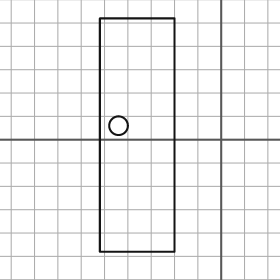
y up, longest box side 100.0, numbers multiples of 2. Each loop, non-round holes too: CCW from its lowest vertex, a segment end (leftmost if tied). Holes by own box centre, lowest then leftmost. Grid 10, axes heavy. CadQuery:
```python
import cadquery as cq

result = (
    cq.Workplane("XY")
    .moveTo(-52.0, -48.0)
    .lineTo(-20.0, -48.0)
    .lineTo(-20.0, 52.0)
    .lineTo(-52.0, 52.0)
    .close()
    .moveTo(-44.0, 6.0)
    .circle(4.0)
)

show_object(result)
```